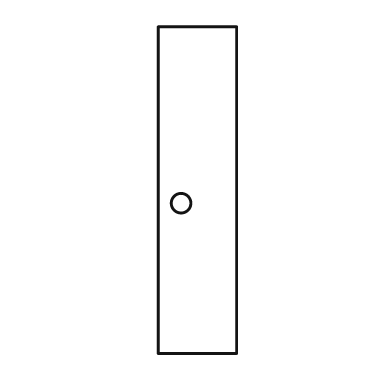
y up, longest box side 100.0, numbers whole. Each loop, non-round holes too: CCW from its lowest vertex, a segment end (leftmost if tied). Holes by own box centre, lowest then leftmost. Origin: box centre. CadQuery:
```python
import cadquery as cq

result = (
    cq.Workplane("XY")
    .moveTo(-12.0, -50.0)
    .lineTo(12.0, -50.0)
    .lineTo(12.0, 50.0)
    .lineTo(-12.0, 50.0)
    .close()
    .moveTo(-5.0, -4.0)
    .circle(3.0)
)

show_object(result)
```